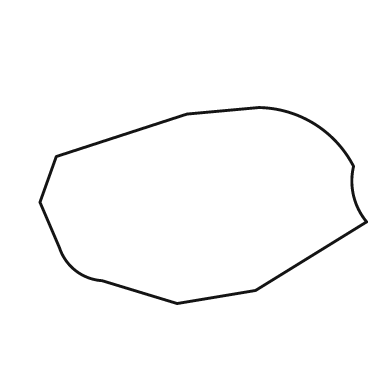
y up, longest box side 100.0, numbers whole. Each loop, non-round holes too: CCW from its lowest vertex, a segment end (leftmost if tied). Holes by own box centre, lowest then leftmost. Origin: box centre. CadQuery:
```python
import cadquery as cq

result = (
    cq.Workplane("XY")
    .moveTo(-8.0, -30.0)
    .lineTo(16.0, -26.0)
    .lineTo(50.0, -5.0)
    .threePointArc((46.0, 3.0), (46.0, 12.0))
    .threePointArc((34.0, 25.0), (17.0, 30.0))
    .lineTo(-5.0, 28.0)
    .lineTo(-45.0, 15.0)
    .lineTo(-50.0, 1.0)
    .lineTo(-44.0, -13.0)
    .threePointArc((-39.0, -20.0), (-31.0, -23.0))
    .close()
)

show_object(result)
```